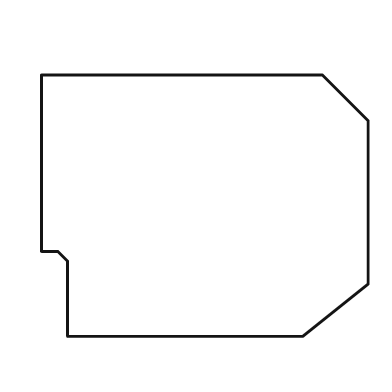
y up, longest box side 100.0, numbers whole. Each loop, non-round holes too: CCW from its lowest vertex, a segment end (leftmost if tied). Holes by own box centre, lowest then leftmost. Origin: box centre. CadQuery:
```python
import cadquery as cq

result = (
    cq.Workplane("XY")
    .moveTo(-42.0, -40.0)
    .lineTo(30.0, -40.0)
    .lineTo(50.0, -24.0)
    .lineTo(50.0, 26.0)
    .lineTo(36.0, 40.0)
    .lineTo(-50.0, 40.0)
    .lineTo(-50.0, -14.0)
    .lineTo(-45.0, -14.0)
    .lineTo(-42.0, -17.0)
    .close()
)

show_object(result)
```